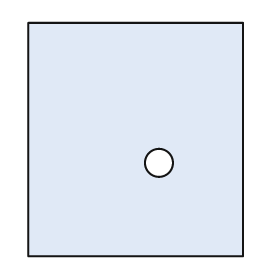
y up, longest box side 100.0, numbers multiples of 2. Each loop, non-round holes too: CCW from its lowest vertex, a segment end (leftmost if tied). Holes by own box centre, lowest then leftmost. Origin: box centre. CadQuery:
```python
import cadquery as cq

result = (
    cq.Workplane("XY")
    .moveTo(-46.0, -50.0)
    .lineTo(46.0, -50.0)
    .lineTo(46.0, 50.0)
    .lineTo(-46.0, 50.0)
    .close()
    .moveTo(10.0, -10.0)
    .circle(6.0)
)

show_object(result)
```